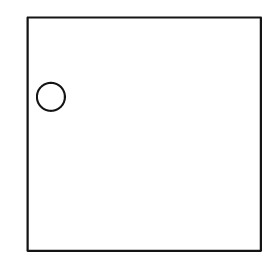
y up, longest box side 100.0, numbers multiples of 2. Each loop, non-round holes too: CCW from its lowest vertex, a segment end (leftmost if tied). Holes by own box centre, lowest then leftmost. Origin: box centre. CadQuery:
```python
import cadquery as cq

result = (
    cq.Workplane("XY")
    .moveTo(-50.0, -50.0)
    .lineTo(50.0, -50.0)
    .lineTo(50.0, 50.0)
    .lineTo(-50.0, 50.0)
    .close()
    .moveTo(-40.0, 16.0)
    .circle(6.0)
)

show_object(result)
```